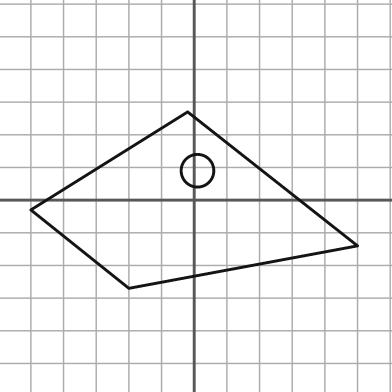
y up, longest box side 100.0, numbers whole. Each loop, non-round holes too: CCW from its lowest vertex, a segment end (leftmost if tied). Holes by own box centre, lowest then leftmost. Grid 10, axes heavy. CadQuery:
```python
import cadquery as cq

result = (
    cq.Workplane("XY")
    .moveTo(-20.0, -27.0)
    .lineTo(50.0, -14.0)
    .lineTo(-2.0, 27.0)
    .lineTo(-50.0, -3.0)
    .close()
    .moveTo(1.0, 9.0)
    .circle(5.0)
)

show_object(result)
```